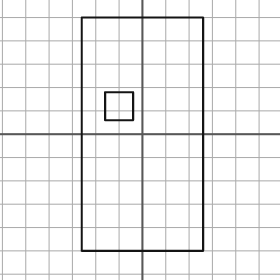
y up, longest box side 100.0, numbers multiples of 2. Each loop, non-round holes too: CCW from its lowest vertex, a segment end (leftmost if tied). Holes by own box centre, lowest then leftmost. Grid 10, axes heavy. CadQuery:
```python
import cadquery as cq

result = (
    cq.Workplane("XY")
    .moveTo(-26.0, -50.0)
    .lineTo(26.0, -50.0)
    .lineTo(26.0, 50.0)
    .lineTo(-26.0, 50.0)
    .close()
    .moveTo(-16.0, 6.0)
    .lineTo(-4.0, 6.0)
    .lineTo(-4.0, 18.0)
    .lineTo(-16.0, 18.0)
    .close()
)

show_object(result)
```